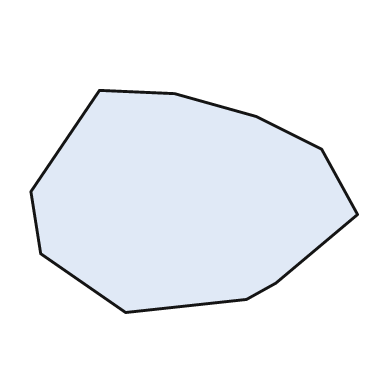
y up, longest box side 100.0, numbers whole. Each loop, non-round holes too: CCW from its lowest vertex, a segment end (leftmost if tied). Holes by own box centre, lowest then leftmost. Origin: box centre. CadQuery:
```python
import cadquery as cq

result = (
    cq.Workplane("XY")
    .moveTo(-21.0, -34.0)
    .lineTo(16.0, -30.0)
    .lineTo(25.0, -25.0)
    .lineTo(50.0, -4.0)
    .lineTo(39.0, 16.0)
    .lineTo(19.0, 26.0)
    .lineTo(-6.0, 33.0)
    .lineTo(-29.0, 34.0)
    .lineTo(-50.0, 3.0)
    .lineTo(-47.0, -16.0)
    .close()
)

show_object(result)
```